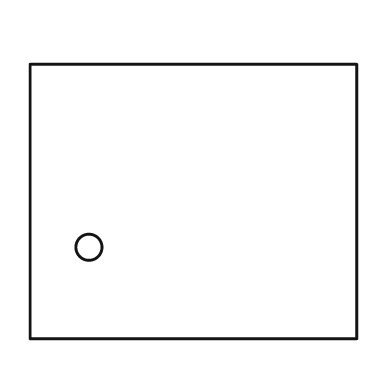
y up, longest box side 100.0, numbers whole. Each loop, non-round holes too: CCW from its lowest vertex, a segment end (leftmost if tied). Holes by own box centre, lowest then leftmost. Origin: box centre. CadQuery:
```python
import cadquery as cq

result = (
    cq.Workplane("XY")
    .moveTo(-50.0, -42.0)
    .lineTo(50.0, -42.0)
    .lineTo(50.0, 42.0)
    .lineTo(-50.0, 42.0)
    .close()
    .moveTo(-32.0, -14.0)
    .circle(4.0)
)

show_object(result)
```